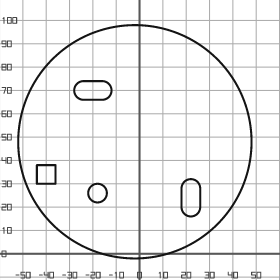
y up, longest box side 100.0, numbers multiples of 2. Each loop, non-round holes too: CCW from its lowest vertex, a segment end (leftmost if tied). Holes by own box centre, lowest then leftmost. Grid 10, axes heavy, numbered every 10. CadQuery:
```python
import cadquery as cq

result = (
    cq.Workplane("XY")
    .moveTo(-2.0, 48.0)
    .circle(50.0)
    .moveTo(18.0, 20.0)
    .threePointArc((22.0, 16.0), (26.0, 20.0))
    .lineTo(26.0, 28.0)
    .threePointArc((22.0, 32.0), (18.0, 28.0))
    .close()
    .moveTo(-18.0, 26.0)
    .circle(4.0)
    .moveTo(-44.0, 30.0)
    .lineTo(-36.0, 30.0)
    .lineTo(-36.0, 38.0)
    .lineTo(-44.0, 38.0)
    .close()
    .moveTo(-24.0, 66.0)
    .lineTo(-16.0, 66.0)
    .threePointArc((-12.0, 70.0), (-16.0, 74.0))
    .lineTo(-24.0, 74.0)
    .threePointArc((-28.0, 70.0), (-24.0, 66.0))
    .close()
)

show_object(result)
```